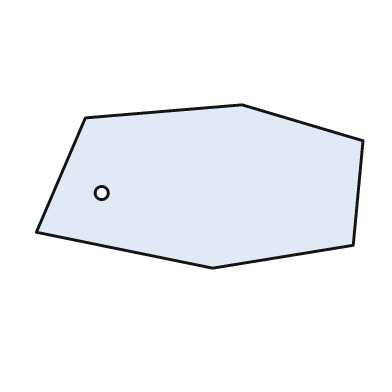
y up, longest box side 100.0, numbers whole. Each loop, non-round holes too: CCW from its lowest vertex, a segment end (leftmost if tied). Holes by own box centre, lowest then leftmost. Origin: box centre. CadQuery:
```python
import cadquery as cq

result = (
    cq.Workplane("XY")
    .moveTo(4.0, -25.0)
    .lineTo(47.0, -18.0)
    .lineTo(50.0, 14.0)
    .lineTo(13.0, 25.0)
    .lineTo(-35.0, 21.0)
    .lineTo(-50.0, -14.0)
    .close()
    .moveTo(-30.0, -2.0)
    .circle(2.0)
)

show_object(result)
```